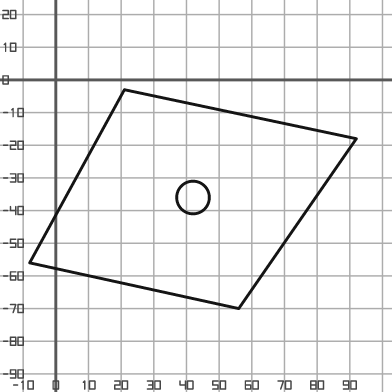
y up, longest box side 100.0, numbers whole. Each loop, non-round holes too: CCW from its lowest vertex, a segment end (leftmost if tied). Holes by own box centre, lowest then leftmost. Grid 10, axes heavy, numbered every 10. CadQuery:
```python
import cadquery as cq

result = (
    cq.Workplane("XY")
    .moveTo(56.0, -70.0)
    .lineTo(92.0, -18.0)
    .lineTo(21.0, -3.0)
    .lineTo(-8.0, -56.0)
    .close()
    .moveTo(42.0, -36.0)
    .circle(5.0)
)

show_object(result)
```